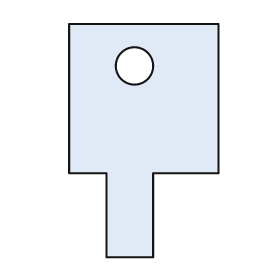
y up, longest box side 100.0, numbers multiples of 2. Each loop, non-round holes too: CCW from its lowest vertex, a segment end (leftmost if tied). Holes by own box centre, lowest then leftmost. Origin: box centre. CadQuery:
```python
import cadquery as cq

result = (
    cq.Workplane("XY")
    .moveTo(-16.0, -50.0)
    .lineTo(4.0, -50.0)
    .lineTo(4.0, -14.0)
    .lineTo(32.0, -14.0)
    .lineTo(32.0, 50.0)
    .lineTo(-32.0, 50.0)
    .lineTo(-32.0, -14.0)
    .lineTo(-16.0, -14.0)
    .close()
    .moveTo(-4.0, 32.0)
    .circle(8.0)
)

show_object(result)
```